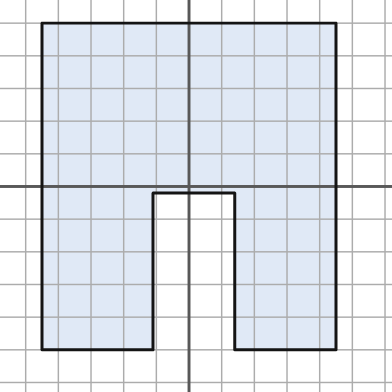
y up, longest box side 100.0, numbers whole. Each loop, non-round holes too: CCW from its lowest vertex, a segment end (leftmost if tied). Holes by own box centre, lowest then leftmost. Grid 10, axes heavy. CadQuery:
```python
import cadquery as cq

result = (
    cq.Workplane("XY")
    .moveTo(-45.0, -50.0)
    .lineTo(-11.0, -50.0)
    .lineTo(-11.0, -2.0)
    .lineTo(14.0, -2.0)
    .lineTo(14.0, -50.0)
    .lineTo(45.0, -50.0)
    .lineTo(45.0, 50.0)
    .lineTo(-45.0, 50.0)
    .close()
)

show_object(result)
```